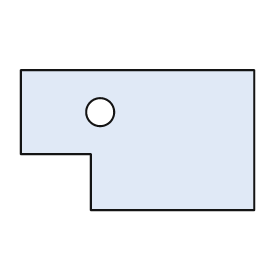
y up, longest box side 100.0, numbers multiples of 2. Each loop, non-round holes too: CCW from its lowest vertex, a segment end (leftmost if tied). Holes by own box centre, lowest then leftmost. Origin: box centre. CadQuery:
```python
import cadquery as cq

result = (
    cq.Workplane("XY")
    .moveTo(-20.0, -30.0)
    .lineTo(50.0, -30.0)
    .lineTo(50.0, 30.0)
    .lineTo(-50.0, 30.0)
    .lineTo(-50.0, -6.0)
    .lineTo(-20.0, -6.0)
    .close()
    .moveTo(-16.0, 12.0)
    .circle(6.0)
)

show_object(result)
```